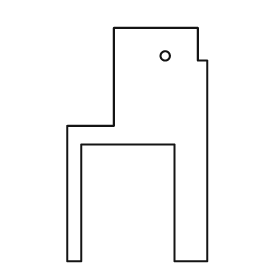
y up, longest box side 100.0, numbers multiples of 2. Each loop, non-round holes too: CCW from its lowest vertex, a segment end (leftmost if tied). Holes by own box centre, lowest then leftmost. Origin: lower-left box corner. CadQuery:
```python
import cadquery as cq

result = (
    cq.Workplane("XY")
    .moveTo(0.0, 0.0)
    .lineTo(6.0, 0.0)
    .lineTo(6.0, 50.0)
    .lineTo(46.0, 50.0)
    .lineTo(46.0, 0.0)
    .lineTo(60.0, 0.0)
    .lineTo(60.0, 86.0)
    .lineTo(56.0, 86.0)
    .lineTo(56.0, 100.0)
    .lineTo(20.0, 100.0)
    .lineTo(20.0, 58.0)
    .lineTo(0.0, 58.0)
    .close()
    .moveTo(42.0, 88.0)
    .circle(2.0)
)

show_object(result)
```